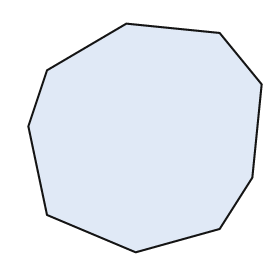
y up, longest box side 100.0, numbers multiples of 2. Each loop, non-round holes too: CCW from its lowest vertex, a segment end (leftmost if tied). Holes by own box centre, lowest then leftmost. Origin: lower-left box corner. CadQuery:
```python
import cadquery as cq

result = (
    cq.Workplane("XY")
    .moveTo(46.0, 0.0)
    .lineTo(82.0, 10.0)
    .lineTo(96.0, 32.0)
    .lineTo(100.0, 72.0)
    .lineTo(82.0, 94.0)
    .lineTo(42.0, 98.0)
    .lineTo(8.0, 78.0)
    .lineTo(0.0, 54.0)
    .lineTo(8.0, 16.0)
    .close()
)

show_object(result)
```